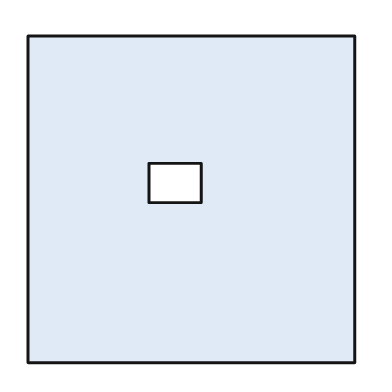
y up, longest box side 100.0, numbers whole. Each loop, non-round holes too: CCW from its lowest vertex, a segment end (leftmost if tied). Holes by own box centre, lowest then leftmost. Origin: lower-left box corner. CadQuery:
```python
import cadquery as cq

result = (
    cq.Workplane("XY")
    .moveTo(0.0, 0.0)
    .lineTo(100.0, 0.0)
    .lineTo(100.0, 100.0)
    .lineTo(0.0, 100.0)
    .close()
    .moveTo(37.0, 49.0)
    .lineTo(53.0, 49.0)
    .lineTo(53.0, 61.0)
    .lineTo(37.0, 61.0)
    .close()
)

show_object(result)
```